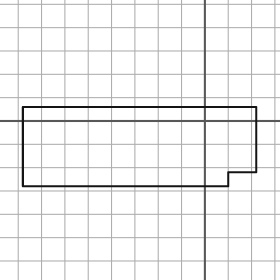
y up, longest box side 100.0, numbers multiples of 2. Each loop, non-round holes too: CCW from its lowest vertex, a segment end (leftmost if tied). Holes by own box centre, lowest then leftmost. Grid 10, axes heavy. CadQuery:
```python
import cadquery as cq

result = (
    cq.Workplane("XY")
    .moveTo(-78.0, -28.0)
    .lineTo(10.0, -28.0)
    .lineTo(10.0, -22.0)
    .lineTo(22.0, -22.0)
    .lineTo(22.0, 6.0)
    .lineTo(-78.0, 6.0)
    .close()
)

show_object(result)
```